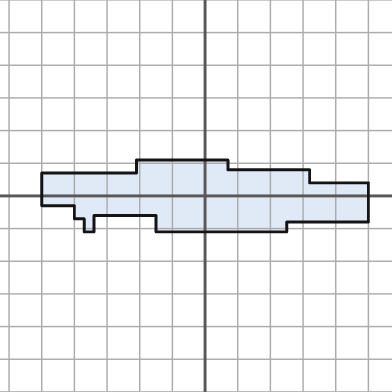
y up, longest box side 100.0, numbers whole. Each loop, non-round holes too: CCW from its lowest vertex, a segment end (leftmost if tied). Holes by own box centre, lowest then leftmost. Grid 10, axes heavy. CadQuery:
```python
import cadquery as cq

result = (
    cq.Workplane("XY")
    .moveTo(-37.0, -11.0)
    .lineTo(-34.0, -11.0)
    .lineTo(-34.0, -6.0)
    .lineTo(-15.0, -6.0)
    .lineTo(-15.0, -11.0)
    .lineTo(25.0, -11.0)
    .lineTo(25.0, -8.0)
    .lineTo(50.0, -8.0)
    .lineTo(50.0, 4.0)
    .lineTo(32.0, 4.0)
    .lineTo(32.0, 8.0)
    .lineTo(7.0, 8.0)
    .lineTo(7.0, 11.0)
    .lineTo(-21.0, 11.0)
    .lineTo(-21.0, 7.0)
    .lineTo(-50.0, 7.0)
    .lineTo(-50.0, -3.0)
    .lineTo(-40.0, -3.0)
    .lineTo(-40.0, -7.0)
    .lineTo(-37.0, -7.0)
    .close()
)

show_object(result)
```